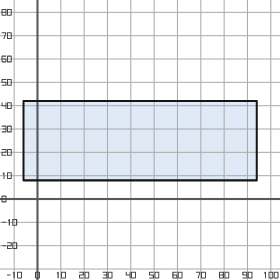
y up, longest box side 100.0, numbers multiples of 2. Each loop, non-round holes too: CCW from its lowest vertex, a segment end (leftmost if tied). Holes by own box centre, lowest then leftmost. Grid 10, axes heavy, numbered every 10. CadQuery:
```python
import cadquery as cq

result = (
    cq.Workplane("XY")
    .moveTo(-6.0, 8.0)
    .lineTo(94.0, 8.0)
    .lineTo(94.0, 42.0)
    .lineTo(-6.0, 42.0)
    .close()
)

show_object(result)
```